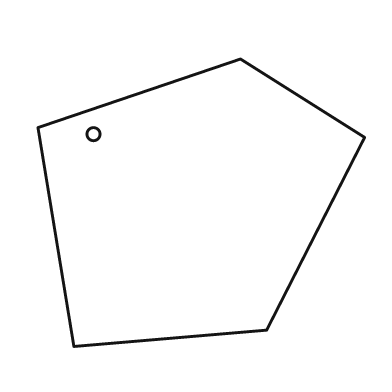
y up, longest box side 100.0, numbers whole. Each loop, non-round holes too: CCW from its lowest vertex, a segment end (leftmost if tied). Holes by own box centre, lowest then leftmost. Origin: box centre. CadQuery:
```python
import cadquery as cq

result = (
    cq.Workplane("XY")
    .moveTo(-39.0, -44.0)
    .lineTo(20.0, -39.0)
    .lineTo(50.0, 20.0)
    .lineTo(12.0, 44.0)
    .lineTo(-50.0, 23.0)
    .close()
    .moveTo(-33.0, 21.0)
    .circle(2.0)
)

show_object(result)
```